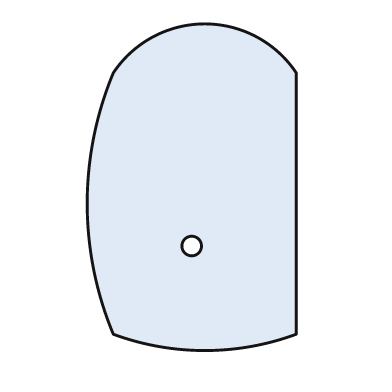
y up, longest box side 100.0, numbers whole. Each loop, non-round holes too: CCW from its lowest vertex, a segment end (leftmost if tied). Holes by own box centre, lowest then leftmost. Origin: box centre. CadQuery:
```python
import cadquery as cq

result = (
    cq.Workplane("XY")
    .moveTo(-24.0, -45.0)
    .threePointArc((4.0, -50.0), (32.0, -45.0))
    .lineTo(32.0, 35.0)
    .threePointArc((4.0, 50.0), (-24.0, 35.0))
    .threePointArc((-32.0, -5.0), (-24.0, -45.0))
    .close()
    .moveTo(0.0, -18.0)
    .circle(3.0)
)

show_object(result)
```